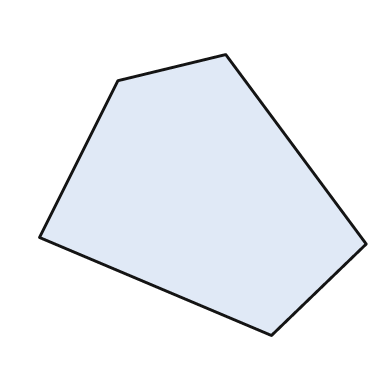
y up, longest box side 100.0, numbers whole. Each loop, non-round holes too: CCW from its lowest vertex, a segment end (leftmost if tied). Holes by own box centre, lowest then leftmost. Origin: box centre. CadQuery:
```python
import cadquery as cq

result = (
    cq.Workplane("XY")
    .moveTo(21.0, -43.0)
    .lineTo(50.0, -15.0)
    .lineTo(7.0, 43.0)
    .lineTo(-26.0, 35.0)
    .lineTo(-50.0, -13.0)
    .close()
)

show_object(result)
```